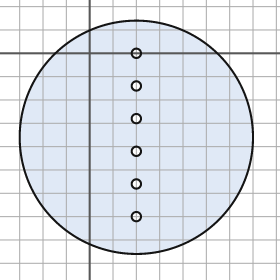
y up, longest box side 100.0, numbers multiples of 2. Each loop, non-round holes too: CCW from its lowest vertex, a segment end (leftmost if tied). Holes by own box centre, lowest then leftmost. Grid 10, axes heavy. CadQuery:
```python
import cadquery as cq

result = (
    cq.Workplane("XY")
    .moveTo(20.0, -36.0)
    .circle(50.0)
    .moveTo(20.0, -70.0)
    .circle(2.0)
    .moveTo(20.0, -56.0)
    .circle(2.0)
    .moveTo(20.0, -42.0)
    .circle(2.0)
    .moveTo(20.0, -28.0)
    .circle(2.0)
    .moveTo(20.0, -14.0)
    .circle(2.0)
    .moveTo(20.0, 0.0)
    .circle(2.0)
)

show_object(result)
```